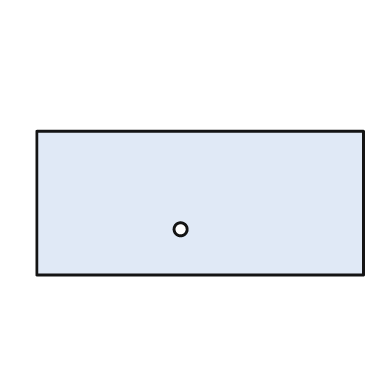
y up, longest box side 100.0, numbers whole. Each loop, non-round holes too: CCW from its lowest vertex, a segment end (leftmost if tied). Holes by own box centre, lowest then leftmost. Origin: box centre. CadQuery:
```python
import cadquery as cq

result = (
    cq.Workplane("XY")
    .moveTo(-50.0, -22.0)
    .lineTo(50.0, -22.0)
    .lineTo(50.0, 22.0)
    .lineTo(-50.0, 22.0)
    .close()
    .moveTo(-6.0, -8.0)
    .circle(2.0)
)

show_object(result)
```